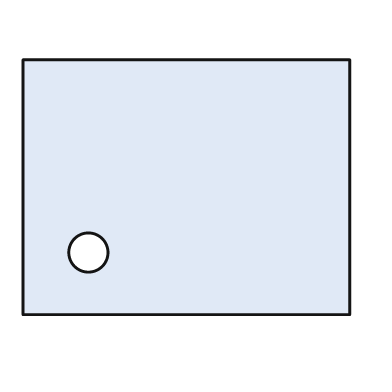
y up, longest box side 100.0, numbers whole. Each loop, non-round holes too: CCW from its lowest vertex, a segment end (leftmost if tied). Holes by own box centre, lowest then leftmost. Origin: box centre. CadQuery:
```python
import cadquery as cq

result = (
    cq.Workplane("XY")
    .moveTo(-50.0, -39.0)
    .lineTo(50.0, -39.0)
    .lineTo(50.0, 39.0)
    .lineTo(-50.0, 39.0)
    .close()
    .moveTo(-30.0, -20.0)
    .circle(6.0)
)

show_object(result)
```